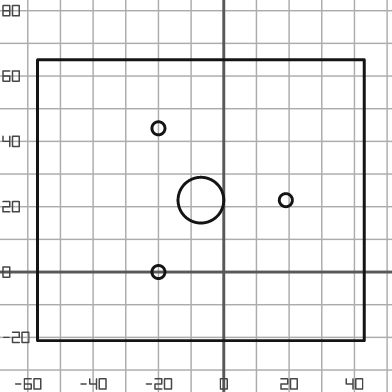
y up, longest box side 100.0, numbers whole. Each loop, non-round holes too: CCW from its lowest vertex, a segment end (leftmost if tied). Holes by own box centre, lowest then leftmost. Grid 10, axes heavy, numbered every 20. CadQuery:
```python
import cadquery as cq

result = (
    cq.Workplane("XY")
    .moveTo(-57.0, -21.0)
    .lineTo(43.0, -21.0)
    .lineTo(43.0, 65.0)
    .lineTo(-57.0, 65.0)
    .close()
    .moveTo(-20.0, 0.0)
    .circle(2.0)
    .moveTo(-7.0, 22.0)
    .circle(7.0)
    .moveTo(19.0, 22.0)
    .circle(2.0)
    .moveTo(-20.0, 44.0)
    .circle(2.0)
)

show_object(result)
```